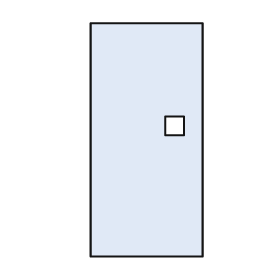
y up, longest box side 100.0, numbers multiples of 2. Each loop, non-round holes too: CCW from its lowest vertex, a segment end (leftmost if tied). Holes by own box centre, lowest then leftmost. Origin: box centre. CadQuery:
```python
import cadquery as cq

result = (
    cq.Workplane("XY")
    .moveTo(-24.0, -50.0)
    .lineTo(24.0, -50.0)
    .lineTo(24.0, 50.0)
    .lineTo(-24.0, 50.0)
    .close()
    .moveTo(8.0, 2.0)
    .lineTo(16.0, 2.0)
    .lineTo(16.0, 10.0)
    .lineTo(8.0, 10.0)
    .close()
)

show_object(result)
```